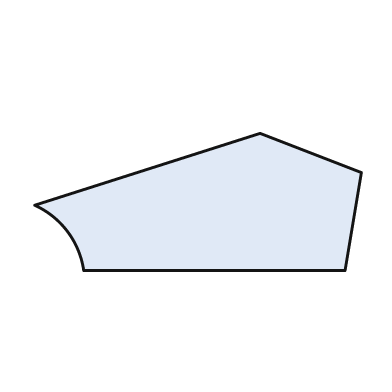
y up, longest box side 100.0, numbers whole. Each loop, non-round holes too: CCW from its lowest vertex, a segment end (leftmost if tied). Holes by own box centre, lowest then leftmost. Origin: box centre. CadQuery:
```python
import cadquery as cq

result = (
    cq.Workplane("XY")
    .moveTo(-35.0, -21.0)
    .lineTo(45.0, -21.0)
    .lineTo(50.0, 9.0)
    .lineTo(19.0, 21.0)
    .lineTo(-50.0, -1.0)
    .threePointArc((-40.0, -9.0), (-35.0, -21.0))
    .close()
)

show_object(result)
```